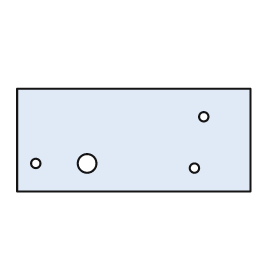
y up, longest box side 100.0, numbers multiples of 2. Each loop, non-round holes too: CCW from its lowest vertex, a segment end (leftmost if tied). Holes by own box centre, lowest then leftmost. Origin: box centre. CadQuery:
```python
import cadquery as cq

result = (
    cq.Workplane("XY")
    .moveTo(-50.0, -22.0)
    .lineTo(50.0, -22.0)
    .lineTo(50.0, 22.0)
    .lineTo(-50.0, 22.0)
    .close()
    .moveTo(26.0, -12.0)
    .circle(2.0)
    .moveTo(-42.0, -10.0)
    .circle(2.0)
    .moveTo(-20.0, -10.0)
    .circle(4.0)
    .moveTo(30.0, 10.0)
    .circle(2.0)
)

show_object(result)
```